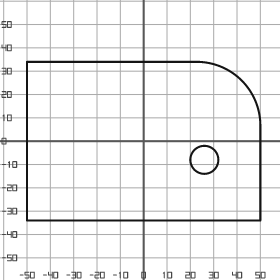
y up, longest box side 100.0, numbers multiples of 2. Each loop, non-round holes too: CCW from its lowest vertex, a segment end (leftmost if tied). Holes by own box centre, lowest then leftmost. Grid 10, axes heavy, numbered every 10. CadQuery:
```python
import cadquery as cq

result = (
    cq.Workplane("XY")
    .moveTo(-50.0, -34.0)
    .lineTo(50.0, -34.0)
    .lineTo(50.0, 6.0)
    .threePointArc((42.0, 26.0), (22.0, 34.0))
    .lineTo(-50.0, 34.0)
    .close()
    .moveTo(26.0, -8.0)
    .circle(6.0)
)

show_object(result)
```